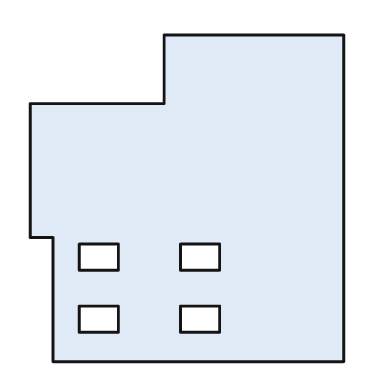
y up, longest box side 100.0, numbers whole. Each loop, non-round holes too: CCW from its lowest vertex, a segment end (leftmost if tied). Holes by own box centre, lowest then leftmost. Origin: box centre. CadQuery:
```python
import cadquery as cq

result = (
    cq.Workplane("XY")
    .moveTo(-41.0, -50.0)
    .lineTo(48.0, -50.0)
    .lineTo(48.0, 50.0)
    .lineTo(-7.0, 50.0)
    .lineTo(-7.0, 29.0)
    .lineTo(-48.0, 29.0)
    .lineTo(-48.0, -12.0)
    .lineTo(-41.0, -12.0)
    .close()
    .moveTo(-33.0, -41.0)
    .lineTo(-21.0, -41.0)
    .lineTo(-21.0, -33.0)
    .lineTo(-33.0, -33.0)
    .close()
    .moveTo(-2.0, -41.0)
    .lineTo(10.0, -41.0)
    .lineTo(10.0, -33.0)
    .lineTo(-2.0, -33.0)
    .close()
    .moveTo(-33.0, -22.0)
    .lineTo(-21.0, -22.0)
    .lineTo(-21.0, -14.0)
    .lineTo(-33.0, -14.0)
    .close()
    .moveTo(-2.0, -22.0)
    .lineTo(10.0, -22.0)
    .lineTo(10.0, -14.0)
    .lineTo(-2.0, -14.0)
    .close()
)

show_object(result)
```